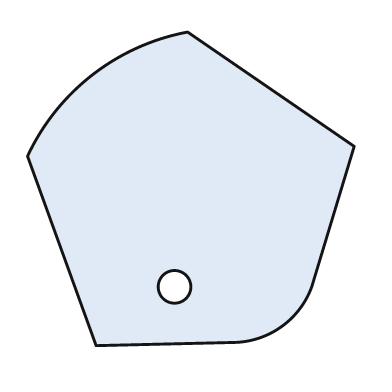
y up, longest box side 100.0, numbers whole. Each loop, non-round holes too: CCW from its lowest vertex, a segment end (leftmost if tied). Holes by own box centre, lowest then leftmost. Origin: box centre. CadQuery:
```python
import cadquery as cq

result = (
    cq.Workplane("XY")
    .moveTo(-29.0, -48.0)
    .lineTo(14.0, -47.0)
    .threePointArc((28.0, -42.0), (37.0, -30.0))
    .lineTo(50.0, 13.0)
    .lineTo(-1.0, 48.0)
    .threePointArc((-30.0, 35.0), (-50.0, 10.0))
    .close()
    .moveTo(-5.0, -30.0)
    .circle(5.0)
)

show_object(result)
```